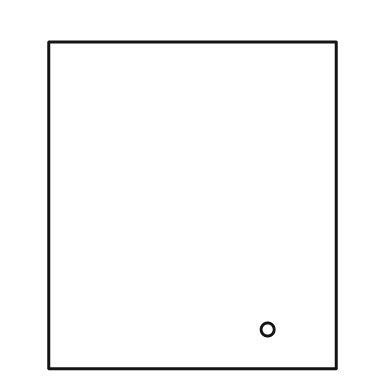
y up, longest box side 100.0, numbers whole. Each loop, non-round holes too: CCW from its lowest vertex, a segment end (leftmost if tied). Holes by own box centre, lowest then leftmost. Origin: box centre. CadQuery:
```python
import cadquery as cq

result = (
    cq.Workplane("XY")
    .moveTo(-44.0, -50.0)
    .lineTo(44.0, -50.0)
    .lineTo(44.0, 50.0)
    .lineTo(-44.0, 50.0)
    .close()
    .moveTo(23.0, -38.0)
    .circle(2.0)
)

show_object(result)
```